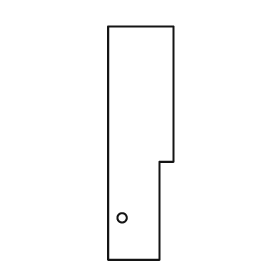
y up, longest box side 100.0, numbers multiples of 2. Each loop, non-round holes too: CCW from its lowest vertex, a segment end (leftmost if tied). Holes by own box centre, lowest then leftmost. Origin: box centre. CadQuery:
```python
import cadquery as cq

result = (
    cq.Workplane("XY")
    .moveTo(-14.0, -50.0)
    .lineTo(8.0, -50.0)
    .lineTo(8.0, -8.0)
    .lineTo(14.0, -8.0)
    .lineTo(14.0, 50.0)
    .lineTo(-14.0, 50.0)
    .close()
    .moveTo(-8.0, -32.0)
    .circle(2.0)
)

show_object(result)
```